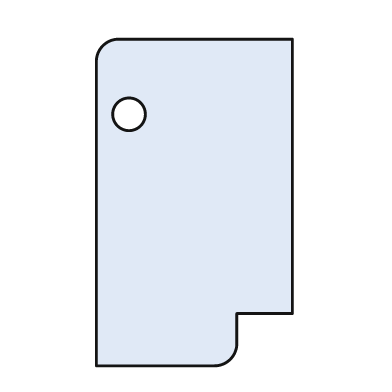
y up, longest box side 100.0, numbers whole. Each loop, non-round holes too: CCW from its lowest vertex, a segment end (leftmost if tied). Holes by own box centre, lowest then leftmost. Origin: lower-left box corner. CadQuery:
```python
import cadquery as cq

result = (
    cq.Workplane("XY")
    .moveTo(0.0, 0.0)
    .lineTo(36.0, 0.0)
    .threePointArc((41.0, 2.0), (43.0, 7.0))
    .lineTo(43.0, 16.0)
    .lineTo(60.0, 16.0)
    .lineTo(60.0, 100.0)
    .lineTo(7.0, 100.0)
    .threePointArc((2.0, 98.0), (0.0, 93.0))
    .close()
    .moveTo(10.0, 77.0)
    .circle(5.0)
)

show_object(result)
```